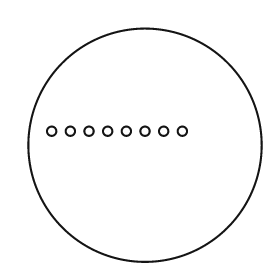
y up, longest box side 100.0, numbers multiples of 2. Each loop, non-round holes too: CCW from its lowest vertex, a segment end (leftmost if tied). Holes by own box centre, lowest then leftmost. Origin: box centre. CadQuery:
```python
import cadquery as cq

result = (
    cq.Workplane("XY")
    .moveTo(0.0, 0.0)
    .circle(50.0)
    .moveTo(-40.0, 6.0)
    .circle(2.0)
    .moveTo(-32.0, 6.0)
    .circle(2.0)
    .moveTo(-24.0, 6.0)
    .circle(2.0)
    .moveTo(-16.0, 6.0)
    .circle(2.0)
    .moveTo(-8.0, 6.0)
    .circle(2.0)
    .moveTo(0.0, 6.0)
    .circle(2.0)
    .moveTo(8.0, 6.0)
    .circle(2.0)
    .moveTo(16.0, 6.0)
    .circle(2.0)
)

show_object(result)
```